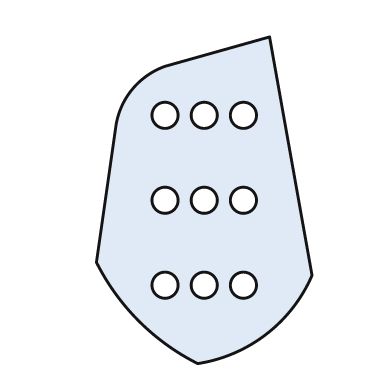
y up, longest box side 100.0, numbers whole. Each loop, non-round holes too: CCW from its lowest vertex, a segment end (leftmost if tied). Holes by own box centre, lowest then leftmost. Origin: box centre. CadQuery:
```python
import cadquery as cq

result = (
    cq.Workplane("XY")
    .moveTo(-2.0, -50.0)
    .threePointArc((19.0, -41.0), (33.0, -23.0))
    .lineTo(20.0, 50.0)
    .lineTo(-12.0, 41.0)
    .threePointArc((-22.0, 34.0), (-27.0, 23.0))
    .lineTo(-33.0, -19.0)
    .threePointArc((-20.0, -37.0), (-2.0, -50.0))
    .close()
    .moveTo(-12.0, -26.0)
    .circle(4.0)
    .moveTo(0.0, -26.0)
    .circle(4.0)
    .moveTo(12.0, -26.0)
    .circle(4.0)
    .moveTo(-12.0, 0.0)
    .circle(4.0)
    .moveTo(0.0, 0.0)
    .circle(4.0)
    .moveTo(12.0, 0.0)
    .circle(4.0)
    .moveTo(-12.0, 26.0)
    .circle(4.0)
    .moveTo(0.0, 26.0)
    .circle(4.0)
    .moveTo(12.0, 26.0)
    .circle(4.0)
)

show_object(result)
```